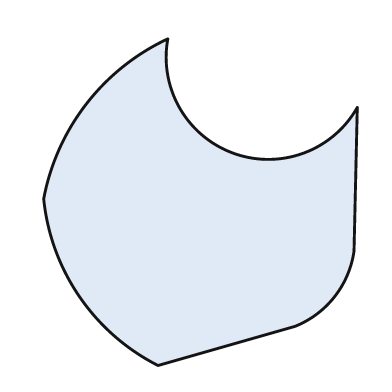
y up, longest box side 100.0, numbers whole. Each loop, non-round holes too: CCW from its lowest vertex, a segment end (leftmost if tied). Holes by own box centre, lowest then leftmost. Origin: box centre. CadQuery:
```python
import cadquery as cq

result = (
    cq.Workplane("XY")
    .moveTo(-13.0, -50.0)
    .lineTo(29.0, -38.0)
    .threePointArc((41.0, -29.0), (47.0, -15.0))
    .lineTo(48.0, 29.0)
    .threePointArc((10.0, 15.0), (-10.0, 50.0))
    .threePointArc((-35.0, 30.0), (-48.0, 1.0))
    .threePointArc((-37.0, -29.0), (-13.0, -50.0))
    .close()
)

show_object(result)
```